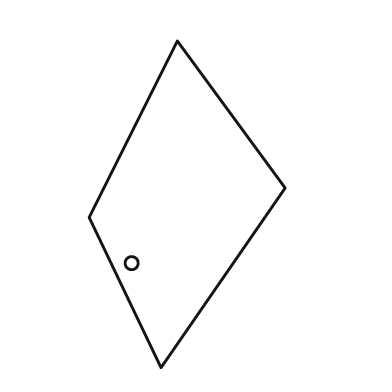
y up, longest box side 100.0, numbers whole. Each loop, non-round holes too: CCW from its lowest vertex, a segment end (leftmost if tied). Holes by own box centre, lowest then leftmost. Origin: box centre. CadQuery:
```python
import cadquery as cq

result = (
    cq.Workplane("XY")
    .moveTo(-8.0, -50.0)
    .lineTo(30.0, 5.0)
    .lineTo(-3.0, 50.0)
    .lineTo(-30.0, -4.0)
    .close()
    .moveTo(-17.0, -18.0)
    .circle(2.0)
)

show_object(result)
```